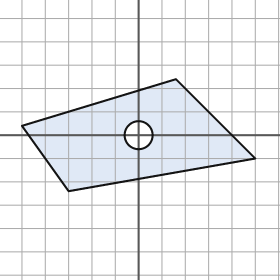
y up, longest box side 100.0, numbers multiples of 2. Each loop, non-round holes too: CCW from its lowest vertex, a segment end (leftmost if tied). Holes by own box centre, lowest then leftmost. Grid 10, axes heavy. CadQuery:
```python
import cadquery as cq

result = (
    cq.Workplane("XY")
    .moveTo(-30.0, -24.0)
    .lineTo(50.0, -10.0)
    .lineTo(16.0, 24.0)
    .lineTo(-50.0, 4.0)
    .close()
    .moveTo(0.0, 0.0)
    .circle(6.0)
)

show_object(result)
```